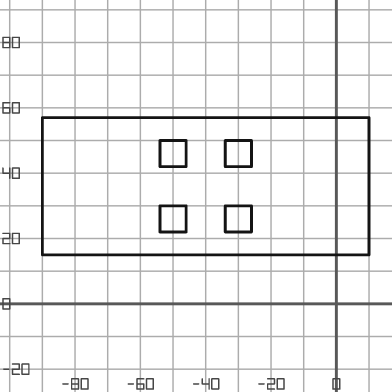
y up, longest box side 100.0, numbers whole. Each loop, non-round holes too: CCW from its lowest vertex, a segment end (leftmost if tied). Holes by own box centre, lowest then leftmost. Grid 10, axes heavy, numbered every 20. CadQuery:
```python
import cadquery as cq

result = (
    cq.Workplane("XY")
    .moveTo(-90.0, 15.0)
    .lineTo(10.0, 15.0)
    .lineTo(10.0, 57.0)
    .lineTo(-90.0, 57.0)
    .close()
    .moveTo(-54.0, 22.0)
    .lineTo(-46.0, 22.0)
    .lineTo(-46.0, 30.0)
    .lineTo(-54.0, 30.0)
    .close()
    .moveTo(-34.0, 22.0)
    .lineTo(-26.0, 22.0)
    .lineTo(-26.0, 30.0)
    .lineTo(-34.0, 30.0)
    .close()
    .moveTo(-54.0, 42.0)
    .lineTo(-46.0, 42.0)
    .lineTo(-46.0, 50.0)
    .lineTo(-54.0, 50.0)
    .close()
    .moveTo(-34.0, 42.0)
    .lineTo(-26.0, 42.0)
    .lineTo(-26.0, 50.0)
    .lineTo(-34.0, 50.0)
    .close()
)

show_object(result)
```